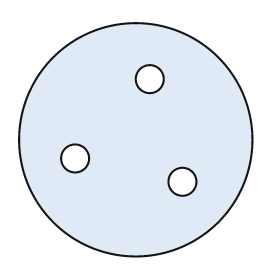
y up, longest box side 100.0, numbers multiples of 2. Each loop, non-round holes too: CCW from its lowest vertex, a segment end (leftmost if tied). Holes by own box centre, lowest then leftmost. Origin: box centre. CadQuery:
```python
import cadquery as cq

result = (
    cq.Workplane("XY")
    .moveTo(0.0, 0.0)
    .circle(50.0)
    .moveTo(20.0, -18.0)
    .circle(6.0)
    .moveTo(-26.0, -8.0)
    .circle(6.0)
    .moveTo(6.0, 26.0)
    .circle(6.0)
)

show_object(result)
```